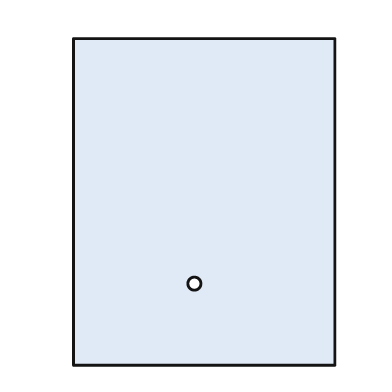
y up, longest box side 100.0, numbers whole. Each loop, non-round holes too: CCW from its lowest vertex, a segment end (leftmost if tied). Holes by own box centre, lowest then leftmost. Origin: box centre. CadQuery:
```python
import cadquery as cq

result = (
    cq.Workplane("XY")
    .moveTo(-40.0, -50.0)
    .lineTo(40.0, -50.0)
    .lineTo(40.0, 50.0)
    .lineTo(-40.0, 50.0)
    .close()
    .moveTo(-3.0, -25.0)
    .circle(2.0)
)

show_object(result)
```